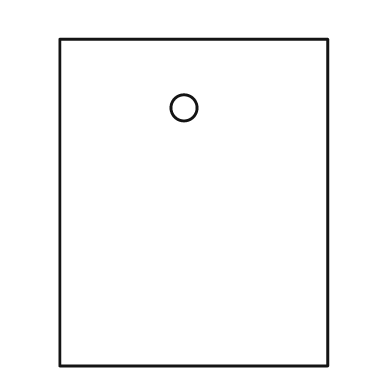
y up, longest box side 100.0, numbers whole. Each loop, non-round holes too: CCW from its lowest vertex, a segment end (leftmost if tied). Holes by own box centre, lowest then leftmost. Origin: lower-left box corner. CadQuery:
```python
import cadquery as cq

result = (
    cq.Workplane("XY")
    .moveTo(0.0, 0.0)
    .lineTo(82.0, 0.0)
    .lineTo(82.0, 100.0)
    .lineTo(0.0, 100.0)
    .close()
    .moveTo(38.0, 79.0)
    .circle(4.0)
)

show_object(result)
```